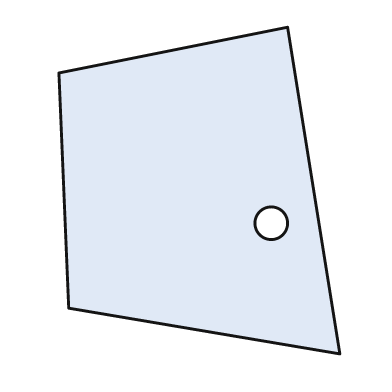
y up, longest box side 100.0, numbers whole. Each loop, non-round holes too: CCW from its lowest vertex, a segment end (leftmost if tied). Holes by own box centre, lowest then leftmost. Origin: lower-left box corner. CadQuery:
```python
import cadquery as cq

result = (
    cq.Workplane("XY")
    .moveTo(86.0, 0.0)
    .lineTo(70.0, 100.0)
    .lineTo(0.0, 86.0)
    .lineTo(3.0, 14.0)
    .close()
    .moveTo(65.0, 40.0)
    .circle(5.0)
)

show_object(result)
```